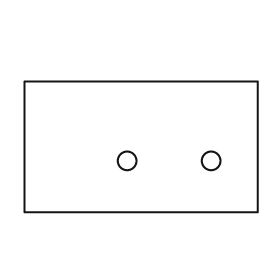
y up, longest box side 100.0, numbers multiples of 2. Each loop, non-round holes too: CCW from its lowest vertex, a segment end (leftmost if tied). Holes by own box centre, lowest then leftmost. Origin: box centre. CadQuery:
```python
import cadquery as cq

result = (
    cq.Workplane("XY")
    .moveTo(-50.0, -28.0)
    .lineTo(50.0, -28.0)
    .lineTo(50.0, 28.0)
    .lineTo(-50.0, 28.0)
    .close()
    .moveTo(-6.0, -6.0)
    .circle(4.0)
    .moveTo(30.0, -6.0)
    .circle(4.0)
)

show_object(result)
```